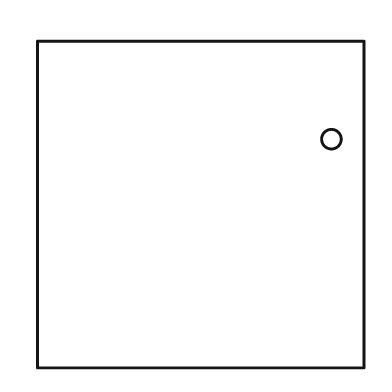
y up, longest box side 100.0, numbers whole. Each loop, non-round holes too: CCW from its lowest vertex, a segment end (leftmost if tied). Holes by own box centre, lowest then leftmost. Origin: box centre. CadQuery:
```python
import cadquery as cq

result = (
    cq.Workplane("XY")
    .moveTo(-50.0, -50.0)
    .lineTo(50.0, -50.0)
    .lineTo(50.0, 50.0)
    .lineTo(-50.0, 50.0)
    .close()
    .moveTo(40.0, 20.0)
    .circle(3.0)
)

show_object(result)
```